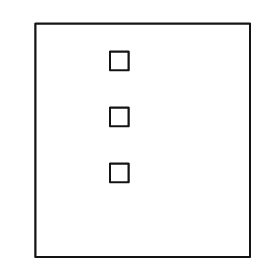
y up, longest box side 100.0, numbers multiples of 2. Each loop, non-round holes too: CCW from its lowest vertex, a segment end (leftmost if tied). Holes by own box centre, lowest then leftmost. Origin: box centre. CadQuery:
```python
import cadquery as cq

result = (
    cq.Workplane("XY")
    .moveTo(-46.0, -50.0)
    .lineTo(46.0, -50.0)
    .lineTo(46.0, 50.0)
    .lineTo(-46.0, 50.0)
    .close()
    .moveTo(-14.0, -18.0)
    .lineTo(-6.0, -18.0)
    .lineTo(-6.0, -10.0)
    .lineTo(-14.0, -10.0)
    .close()
    .moveTo(-14.0, 6.0)
    .lineTo(-6.0, 6.0)
    .lineTo(-6.0, 14.0)
    .lineTo(-14.0, 14.0)
    .close()
    .moveTo(-14.0, 30.0)
    .lineTo(-6.0, 30.0)
    .lineTo(-6.0, 38.0)
    .lineTo(-14.0, 38.0)
    .close()
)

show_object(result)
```